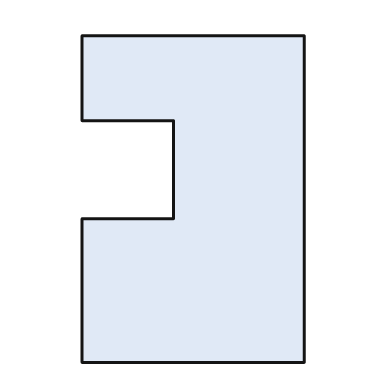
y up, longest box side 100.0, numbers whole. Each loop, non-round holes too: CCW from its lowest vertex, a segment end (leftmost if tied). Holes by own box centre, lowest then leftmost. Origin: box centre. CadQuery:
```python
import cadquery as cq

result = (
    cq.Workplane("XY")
    .moveTo(-34.0, -50.0)
    .lineTo(34.0, -50.0)
    .lineTo(34.0, 50.0)
    .lineTo(-34.0, 50.0)
    .lineTo(-34.0, 24.0)
    .lineTo(-6.0, 24.0)
    .lineTo(-6.0, -6.0)
    .lineTo(-34.0, -6.0)
    .close()
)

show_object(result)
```